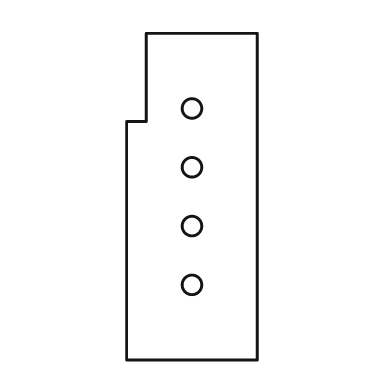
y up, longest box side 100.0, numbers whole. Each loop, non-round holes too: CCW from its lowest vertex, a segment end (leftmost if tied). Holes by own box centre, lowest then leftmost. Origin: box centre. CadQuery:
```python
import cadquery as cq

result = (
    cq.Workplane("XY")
    .moveTo(-20.0, -50.0)
    .lineTo(20.0, -50.0)
    .lineTo(20.0, 50.0)
    .lineTo(-14.0, 50.0)
    .lineTo(-14.0, 23.0)
    .lineTo(-20.0, 23.0)
    .close()
    .moveTo(0.0, -27.0)
    .circle(3.0)
    .moveTo(0.0, -9.0)
    .circle(3.0)
    .moveTo(0.0, 9.0)
    .circle(3.0)
    .moveTo(0.0, 27.0)
    .circle(3.0)
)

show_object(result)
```